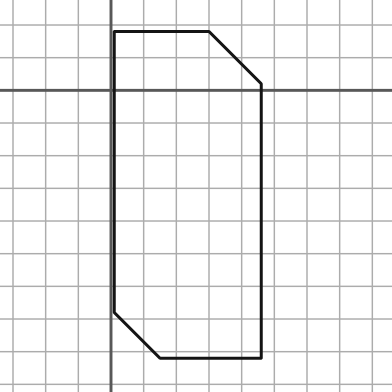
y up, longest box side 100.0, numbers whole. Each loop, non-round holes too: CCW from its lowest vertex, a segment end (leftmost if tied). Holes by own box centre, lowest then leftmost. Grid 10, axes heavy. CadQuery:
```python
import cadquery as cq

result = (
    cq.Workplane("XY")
    .moveTo(15.0, -82.0)
    .lineTo(46.0, -82.0)
    .lineTo(46.0, 2.0)
    .lineTo(30.0, 18.0)
    .lineTo(1.0, 18.0)
    .lineTo(1.0, -68.0)
    .close()
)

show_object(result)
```